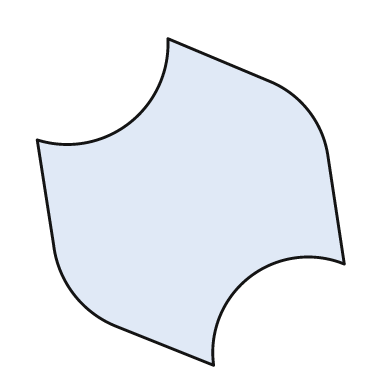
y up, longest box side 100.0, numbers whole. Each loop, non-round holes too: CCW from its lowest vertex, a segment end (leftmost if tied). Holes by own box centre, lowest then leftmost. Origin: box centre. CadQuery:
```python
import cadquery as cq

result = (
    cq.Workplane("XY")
    .moveTo(7.0, -50.0)
    .threePointArc((18.0, -23.0), (47.0, -19.0))
    .lineTo(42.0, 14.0)
    .threePointArc((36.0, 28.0), (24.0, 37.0))
    .lineTo(-7.0, 50.0)
    .threePointArc((-19.0, 24.0), (-47.0, 19.0))
    .lineTo(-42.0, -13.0)
    .threePointArc((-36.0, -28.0), (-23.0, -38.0))
    .close()
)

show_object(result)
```